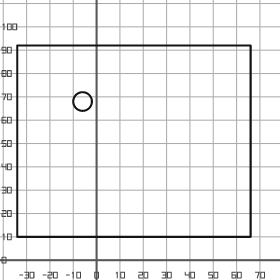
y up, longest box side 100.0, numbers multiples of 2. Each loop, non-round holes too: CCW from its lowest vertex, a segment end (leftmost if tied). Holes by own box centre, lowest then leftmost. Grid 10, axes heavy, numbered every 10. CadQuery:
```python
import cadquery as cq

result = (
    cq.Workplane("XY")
    .moveTo(-34.0, 10.0)
    .lineTo(66.0, 10.0)
    .lineTo(66.0, 92.0)
    .lineTo(-34.0, 92.0)
    .close()
    .moveTo(-6.0, 68.0)
    .circle(4.0)
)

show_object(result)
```